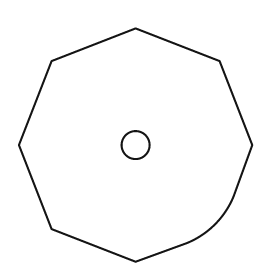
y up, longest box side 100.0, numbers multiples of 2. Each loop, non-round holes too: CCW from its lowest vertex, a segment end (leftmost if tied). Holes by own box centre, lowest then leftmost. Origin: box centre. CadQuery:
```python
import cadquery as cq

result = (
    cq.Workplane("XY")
    .moveTo(0.0, -50.0)
    .lineTo(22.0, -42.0)
    .threePointArc((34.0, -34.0), (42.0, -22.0))
    .lineTo(50.0, 0.0)
    .lineTo(36.0, 36.0)
    .lineTo(0.0, 50.0)
    .lineTo(-36.0, 36.0)
    .lineTo(-50.0, 0.0)
    .lineTo(-36.0, -36.0)
    .close()
    .moveTo(0.0, 0.0)
    .circle(6.0)
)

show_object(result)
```